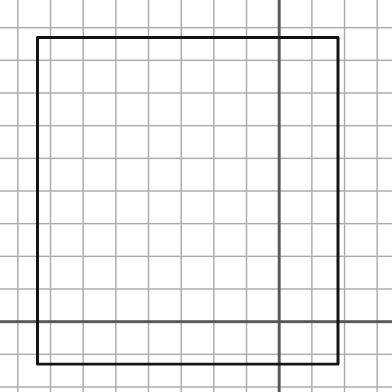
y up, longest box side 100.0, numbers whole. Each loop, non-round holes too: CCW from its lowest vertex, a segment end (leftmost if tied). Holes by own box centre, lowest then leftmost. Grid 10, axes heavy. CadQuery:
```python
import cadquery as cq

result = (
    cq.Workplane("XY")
    .moveTo(-74.0, -13.0)
    .lineTo(18.0, -13.0)
    .lineTo(18.0, 87.0)
    .lineTo(-74.0, 87.0)
    .close()
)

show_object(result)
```